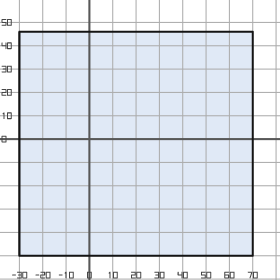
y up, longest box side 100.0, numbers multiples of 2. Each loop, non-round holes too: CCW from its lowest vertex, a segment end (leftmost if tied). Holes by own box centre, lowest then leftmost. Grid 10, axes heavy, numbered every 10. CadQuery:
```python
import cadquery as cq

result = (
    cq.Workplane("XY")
    .moveTo(-30.0, -50.0)
    .lineTo(70.0, -50.0)
    .lineTo(70.0, 46.0)
    .lineTo(-30.0, 46.0)
    .close()
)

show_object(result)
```